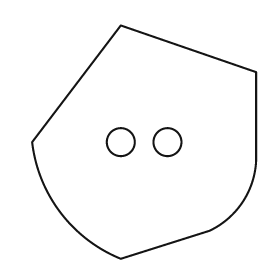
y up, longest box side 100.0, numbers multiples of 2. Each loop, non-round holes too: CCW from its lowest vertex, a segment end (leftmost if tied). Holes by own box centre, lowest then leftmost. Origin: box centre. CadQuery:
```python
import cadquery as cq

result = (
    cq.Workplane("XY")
    .moveTo(-10.0, -50.0)
    .lineTo(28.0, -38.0)
    .threePointArc((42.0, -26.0), (48.0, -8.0))
    .lineTo(48.0, 30.0)
    .lineTo(-10.0, 50.0)
    .lineTo(-48.0, 0.0)
    .threePointArc((-36.0, -30.0), (-10.0, -50.0))
    .close()
    .moveTo(-10.0, 0.0)
    .circle(6.0)
    .moveTo(10.0, 0.0)
    .circle(6.0)
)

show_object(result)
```